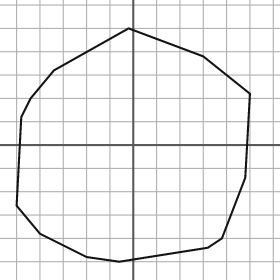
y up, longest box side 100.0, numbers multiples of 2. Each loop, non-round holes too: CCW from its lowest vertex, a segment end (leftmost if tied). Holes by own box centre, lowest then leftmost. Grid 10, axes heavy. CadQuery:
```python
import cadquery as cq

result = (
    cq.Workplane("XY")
    .moveTo(-6.0, -50.0)
    .lineTo(32.0, -44.0)
    .lineTo(38.0, -40.0)
    .lineTo(48.0, -14.0)
    .lineTo(50.0, 22.0)
    .lineTo(30.0, 38.0)
    .lineTo(-2.0, 50.0)
    .lineTo(-34.0, 32.0)
    .lineTo(-44.0, 20.0)
    .lineTo(-48.0, 12.0)
    .lineTo(-50.0, -26.0)
    .lineTo(-40.0, -38.0)
    .lineTo(-20.0, -48.0)
    .close()
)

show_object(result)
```